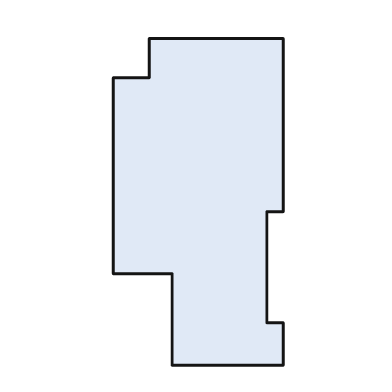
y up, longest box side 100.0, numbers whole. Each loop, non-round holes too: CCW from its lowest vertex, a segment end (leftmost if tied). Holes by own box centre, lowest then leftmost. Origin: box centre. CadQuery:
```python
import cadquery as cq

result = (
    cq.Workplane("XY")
    .moveTo(-8.0, -50.0)
    .lineTo(26.0, -50.0)
    .lineTo(26.0, -37.0)
    .lineTo(21.0, -37.0)
    .lineTo(21.0, -3.0)
    .lineTo(26.0, -3.0)
    .lineTo(26.0, 50.0)
    .lineTo(-15.0, 50.0)
    .lineTo(-15.0, 38.0)
    .lineTo(-26.0, 38.0)
    .lineTo(-26.0, -22.0)
    .lineTo(-8.0, -22.0)
    .close()
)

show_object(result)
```